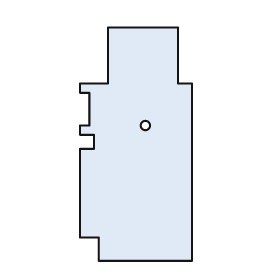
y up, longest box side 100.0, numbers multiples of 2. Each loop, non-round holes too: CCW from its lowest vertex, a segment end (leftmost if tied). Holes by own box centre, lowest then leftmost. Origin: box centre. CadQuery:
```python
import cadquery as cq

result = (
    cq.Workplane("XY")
    .moveTo(-16.0, -50.0)
    .lineTo(24.0, -50.0)
    .lineTo(24.0, 26.0)
    .lineTo(18.0, 26.0)
    .lineTo(18.0, 50.0)
    .lineTo(-12.0, 50.0)
    .lineTo(-12.0, 26.0)
    .lineTo(-24.0, 26.0)
    .lineTo(-24.0, 22.0)
    .lineTo(-20.0, 22.0)
    .lineTo(-20.0, 8.0)
    .lineTo(-24.0, 8.0)
    .lineTo(-24.0, 4.0)
    .lineTo(-18.0, 4.0)
    .lineTo(-18.0, -2.0)
    .lineTo(-24.0, -2.0)
    .lineTo(-24.0, -40.0)
    .lineTo(-16.0, -40.0)
    .close()
    .moveTo(4.0, 8.0)
    .circle(2.0)
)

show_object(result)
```